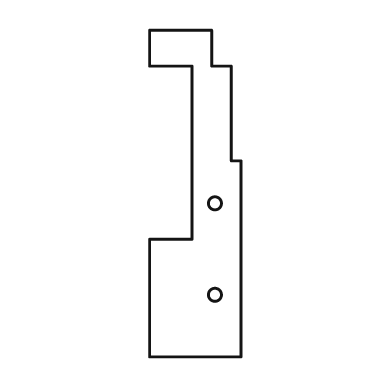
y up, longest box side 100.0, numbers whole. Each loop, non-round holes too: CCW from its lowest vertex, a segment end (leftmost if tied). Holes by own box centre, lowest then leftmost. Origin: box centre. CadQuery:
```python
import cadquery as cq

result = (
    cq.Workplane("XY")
    .moveTo(-14.0, -50.0)
    .lineTo(14.0, -50.0)
    .lineTo(14.0, 10.0)
    .lineTo(11.0, 10.0)
    .lineTo(11.0, 39.0)
    .lineTo(5.0, 39.0)
    .lineTo(5.0, 50.0)
    .lineTo(-14.0, 50.0)
    .lineTo(-14.0, 39.0)
    .lineTo(-1.0, 39.0)
    .lineTo(-1.0, -14.0)
    .lineTo(-14.0, -14.0)
    .close()
    .moveTo(6.0, -31.0)
    .circle(2.0)
    .moveTo(6.0, -3.0)
    .circle(2.0)
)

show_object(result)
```